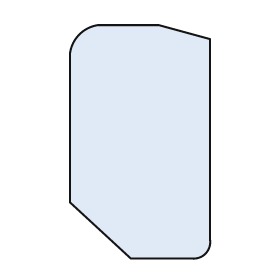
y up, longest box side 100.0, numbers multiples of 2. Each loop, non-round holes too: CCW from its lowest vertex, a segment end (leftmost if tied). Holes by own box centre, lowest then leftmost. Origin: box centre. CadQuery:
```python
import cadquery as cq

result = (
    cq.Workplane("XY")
    .moveTo(-4.0, -50.0)
    .lineTo(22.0, -50.0)
    .threePointArc((28.0, -48.0), (30.0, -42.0))
    .lineTo(30.0, 44.0)
    .lineTo(8.0, 50.0)
    .lineTo(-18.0, 50.0)
    .threePointArc((-26.0, 46.0), (-30.0, 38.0))
    .lineTo(-30.0, -26.0)
    .close()
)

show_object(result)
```